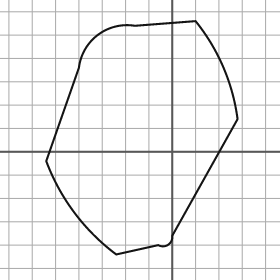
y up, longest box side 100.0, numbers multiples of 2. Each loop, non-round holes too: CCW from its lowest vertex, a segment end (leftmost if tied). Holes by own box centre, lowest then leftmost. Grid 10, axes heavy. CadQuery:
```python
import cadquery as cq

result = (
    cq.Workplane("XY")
    .moveTo(-24.0, -44.0)
    .lineTo(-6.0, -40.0)
    .threePointArc((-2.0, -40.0), (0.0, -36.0))
    .lineTo(28.0, 14.0)
    .threePointArc((22.0, 36.0), (10.0, 56.0))
    .lineTo(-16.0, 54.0)
    .threePointArc((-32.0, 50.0), (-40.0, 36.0))
    .lineTo(-54.0, -4.0)
    .threePointArc((-42.0, -26.0), (-24.0, -44.0))
    .close()
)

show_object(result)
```